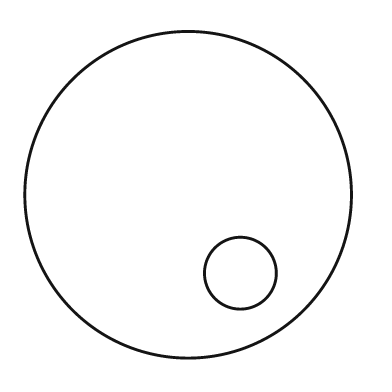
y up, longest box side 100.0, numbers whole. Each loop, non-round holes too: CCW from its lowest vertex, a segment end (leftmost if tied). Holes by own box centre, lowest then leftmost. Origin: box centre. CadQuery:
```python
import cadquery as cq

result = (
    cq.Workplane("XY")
    .moveTo(0.0, 0.0)
    .circle(50.0)
    .moveTo(16.0, -24.0)
    .circle(11.0)
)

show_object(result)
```